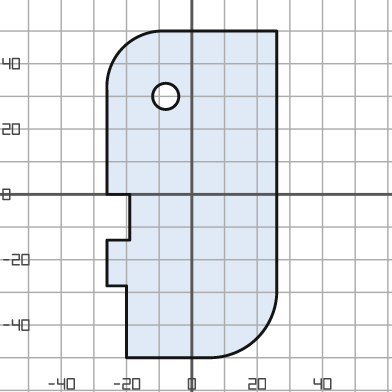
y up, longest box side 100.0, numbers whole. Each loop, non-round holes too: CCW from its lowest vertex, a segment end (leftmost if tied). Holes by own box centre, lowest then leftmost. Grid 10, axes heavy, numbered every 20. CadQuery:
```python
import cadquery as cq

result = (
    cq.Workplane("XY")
    .moveTo(-20.0, -50.0)
    .lineTo(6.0, -50.0)
    .threePointArc((20.0, -44.0), (26.0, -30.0))
    .lineTo(26.0, 50.0)
    .lineTo(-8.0, 50.0)
    .threePointArc((-21.0, 45.0), (-26.0, 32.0))
    .lineTo(-26.0, 0.0)
    .lineTo(-19.0, 0.0)
    .lineTo(-19.0, -14.0)
    .lineTo(-26.0, -14.0)
    .lineTo(-26.0, -28.0)
    .lineTo(-20.0, -28.0)
    .close()
    .moveTo(-8.0, 30.0)
    .circle(4.0)
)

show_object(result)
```